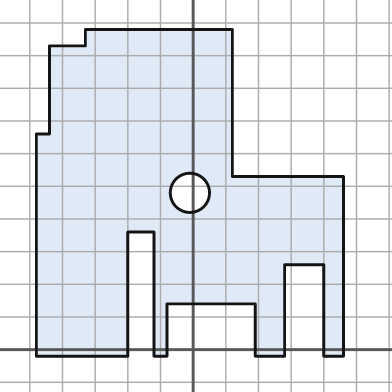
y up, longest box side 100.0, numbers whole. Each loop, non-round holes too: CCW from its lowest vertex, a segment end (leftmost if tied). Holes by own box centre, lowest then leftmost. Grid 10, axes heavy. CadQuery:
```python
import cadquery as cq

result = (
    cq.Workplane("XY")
    .moveTo(-48.0, -2.0)
    .lineTo(-20.0, -2.0)
    .lineTo(-20.0, 36.0)
    .lineTo(-12.0, 36.0)
    .lineTo(-12.0, -2.0)
    .lineTo(-8.0, -2.0)
    .lineTo(-8.0, 14.0)
    .lineTo(19.0, 14.0)
    .lineTo(19.0, -2.0)
    .lineTo(28.0, -2.0)
    .lineTo(28.0, 26.0)
    .lineTo(40.0, 26.0)
    .lineTo(40.0, -2.0)
    .lineTo(46.0, -2.0)
    .lineTo(46.0, 53.0)
    .lineTo(12.0, 53.0)
    .lineTo(12.0, 98.0)
    .lineTo(-33.0, 98.0)
    .lineTo(-33.0, 93.0)
    .lineTo(-44.0, 93.0)
    .lineTo(-44.0, 66.0)
    .lineTo(-48.0, 66.0)
    .close()
    .moveTo(-1.0, 48.0)
    .circle(6.0)
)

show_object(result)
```